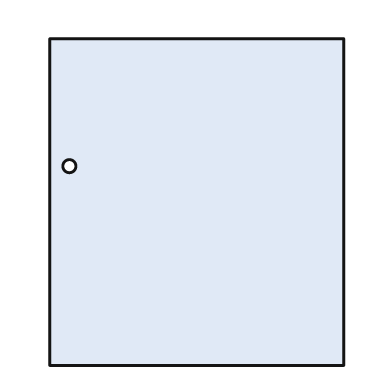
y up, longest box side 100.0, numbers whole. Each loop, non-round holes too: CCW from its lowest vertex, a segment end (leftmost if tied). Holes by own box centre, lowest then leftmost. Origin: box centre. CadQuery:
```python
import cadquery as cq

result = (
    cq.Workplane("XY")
    .moveTo(-45.0, -50.0)
    .lineTo(45.0, -50.0)
    .lineTo(45.0, 50.0)
    .lineTo(-45.0, 50.0)
    .close()
    .moveTo(-39.0, 11.0)
    .circle(2.0)
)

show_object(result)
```